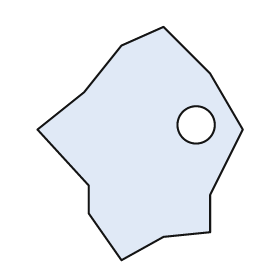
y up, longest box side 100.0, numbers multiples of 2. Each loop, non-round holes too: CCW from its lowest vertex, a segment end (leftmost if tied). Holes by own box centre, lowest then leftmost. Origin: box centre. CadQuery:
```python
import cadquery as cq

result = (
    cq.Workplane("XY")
    .moveTo(-8.0, -50.0)
    .lineTo(10.0, -40.0)
    .lineTo(30.0, -38.0)
    .lineTo(30.0, -22.0)
    .lineTo(44.0, 6.0)
    .lineTo(30.0, 30.0)
    .lineTo(10.0, 50.0)
    .lineTo(-8.0, 42.0)
    .lineTo(-24.0, 22.0)
    .lineTo(-44.0, 6.0)
    .lineTo(-22.0, -18.0)
    .lineTo(-22.0, -30.0)
    .close()
    .moveTo(24.0, 8.0)
    .circle(8.0)
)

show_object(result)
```